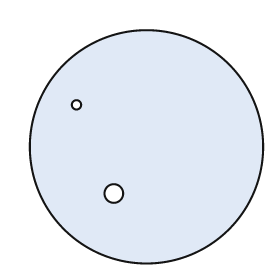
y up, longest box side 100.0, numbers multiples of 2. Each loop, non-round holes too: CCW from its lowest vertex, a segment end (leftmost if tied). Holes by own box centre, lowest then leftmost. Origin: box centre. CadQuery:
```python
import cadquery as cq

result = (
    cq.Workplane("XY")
    .moveTo(0.0, 0.0)
    .circle(50.0)
    .moveTo(-14.0, -20.0)
    .circle(4.0)
    .moveTo(-30.0, 18.0)
    .circle(2.0)
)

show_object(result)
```